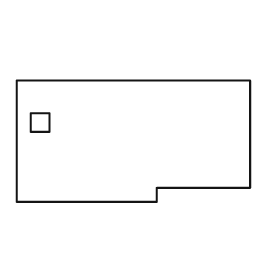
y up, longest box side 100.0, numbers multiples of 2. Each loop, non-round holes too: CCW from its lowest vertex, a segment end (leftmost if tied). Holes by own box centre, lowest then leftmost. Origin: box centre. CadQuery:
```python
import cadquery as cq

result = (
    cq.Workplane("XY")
    .moveTo(-50.0, -26.0)
    .lineTo(10.0, -26.0)
    .lineTo(10.0, -20.0)
    .lineTo(50.0, -20.0)
    .lineTo(50.0, 26.0)
    .lineTo(-50.0, 26.0)
    .close()
    .moveTo(-44.0, 4.0)
    .lineTo(-36.0, 4.0)
    .lineTo(-36.0, 12.0)
    .lineTo(-44.0, 12.0)
    .close()
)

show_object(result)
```